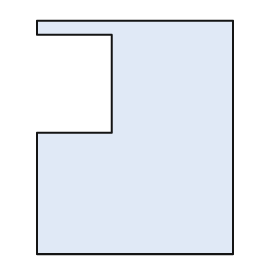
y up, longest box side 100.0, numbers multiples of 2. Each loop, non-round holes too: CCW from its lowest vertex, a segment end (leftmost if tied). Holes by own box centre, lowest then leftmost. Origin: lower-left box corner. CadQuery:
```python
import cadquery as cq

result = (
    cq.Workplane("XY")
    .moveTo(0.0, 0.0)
    .lineTo(84.0, 0.0)
    .lineTo(84.0, 100.0)
    .lineTo(0.0, 100.0)
    .lineTo(0.0, 94.0)
    .lineTo(32.0, 94.0)
    .lineTo(32.0, 52.0)
    .lineTo(0.0, 52.0)
    .close()
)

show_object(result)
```